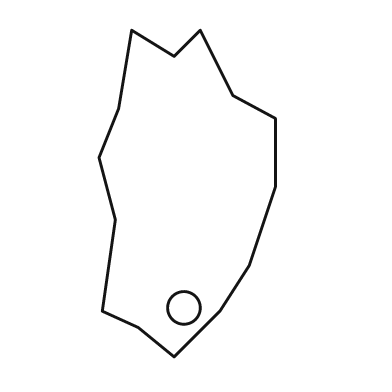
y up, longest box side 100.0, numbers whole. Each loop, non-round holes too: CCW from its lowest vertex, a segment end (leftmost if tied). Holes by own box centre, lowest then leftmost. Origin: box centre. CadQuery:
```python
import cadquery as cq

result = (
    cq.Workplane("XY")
    .moveTo(-4.0, -50.0)
    .lineTo(10.0, -36.0)
    .lineTo(19.0, -22.0)
    .lineTo(27.0, 2.0)
    .lineTo(27.0, 23.0)
    .lineTo(14.0, 30.0)
    .lineTo(4.0, 50.0)
    .lineTo(-4.0, 42.0)
    .lineTo(-17.0, 50.0)
    .lineTo(-21.0, 26.0)
    .lineTo(-27.0, 11.0)
    .lineTo(-22.0, -8.0)
    .lineTo(-26.0, -36.0)
    .lineTo(-15.0, -41.0)
    .close()
    .moveTo(-1.0, -35.0)
    .circle(5.0)
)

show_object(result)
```